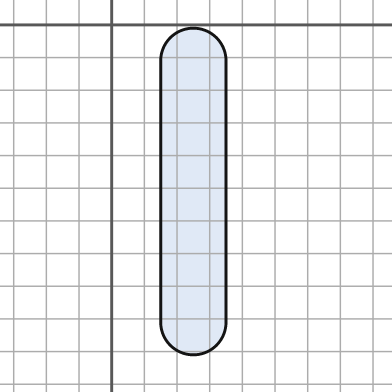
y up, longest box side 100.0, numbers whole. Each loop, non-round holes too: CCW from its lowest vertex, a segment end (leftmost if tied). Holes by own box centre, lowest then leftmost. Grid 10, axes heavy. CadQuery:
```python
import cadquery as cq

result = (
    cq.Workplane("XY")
    .moveTo(15.0, -91.0)
    .threePointArc((25.0, -101.0), (35.0, -91.0))
    .lineTo(35.0, -11.0)
    .threePointArc((25.0, -1.0), (15.0, -11.0))
    .close()
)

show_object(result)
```